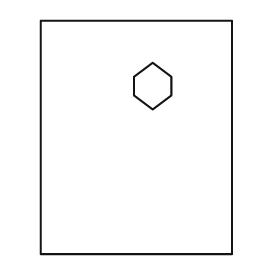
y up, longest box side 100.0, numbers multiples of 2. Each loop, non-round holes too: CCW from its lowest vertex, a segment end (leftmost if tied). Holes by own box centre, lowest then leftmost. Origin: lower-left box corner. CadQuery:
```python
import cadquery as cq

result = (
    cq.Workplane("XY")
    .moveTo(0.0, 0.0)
    .lineTo(82.0, 0.0)
    .lineTo(82.0, 100.0)
    .lineTo(0.0, 100.0)
    .close()
    .moveTo(48.0, 62.0)
    .lineTo(56.0, 68.0)
    .lineTo(56.0, 76.0)
    .lineTo(48.0, 82.0)
    .lineTo(40.0, 76.0)
    .lineTo(40.0, 68.0)
    .close()
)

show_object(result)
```